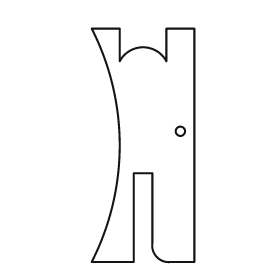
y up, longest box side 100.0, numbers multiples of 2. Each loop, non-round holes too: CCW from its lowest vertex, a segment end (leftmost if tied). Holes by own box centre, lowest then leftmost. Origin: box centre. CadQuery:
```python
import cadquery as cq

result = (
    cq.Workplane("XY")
    .moveTo(-22.0, -50.0)
    .lineTo(-4.0, -50.0)
    .lineTo(-4.0, -12.0)
    .lineTo(4.0, -12.0)
    .lineTo(4.0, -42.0)
    .threePointArc((6.0, -48.0), (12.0, -50.0))
    .lineTo(22.0, -50.0)
    .lineTo(22.0, 50.0)
    .lineTo(10.0, 50.0)
    .lineTo(10.0, 36.0)
    .threePointArc((0.0, 42.0), (-10.0, 36.0))
    .lineTo(-10.0, 50.0)
    .lineTo(-22.0, 50.0)
    .threePointArc((-10.0, 0.0), (-22.0, -50.0))
    .close()
    .moveTo(16.0, 6.0)
    .circle(2.0)
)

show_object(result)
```